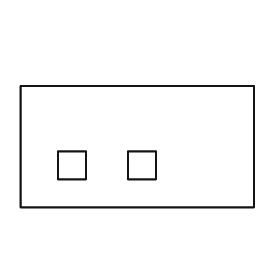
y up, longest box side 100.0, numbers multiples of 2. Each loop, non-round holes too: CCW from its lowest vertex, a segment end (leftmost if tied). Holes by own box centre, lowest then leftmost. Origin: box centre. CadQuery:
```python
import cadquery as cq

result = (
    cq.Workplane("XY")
    .moveTo(-50.0, -26.0)
    .lineTo(50.0, -26.0)
    .lineTo(50.0, 26.0)
    .lineTo(-50.0, 26.0)
    .close()
    .moveTo(-34.0, -14.0)
    .lineTo(-22.0, -14.0)
    .lineTo(-22.0, -2.0)
    .lineTo(-34.0, -2.0)
    .close()
    .moveTo(-4.0, -14.0)
    .lineTo(8.0, -14.0)
    .lineTo(8.0, -2.0)
    .lineTo(-4.0, -2.0)
    .close()
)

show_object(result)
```